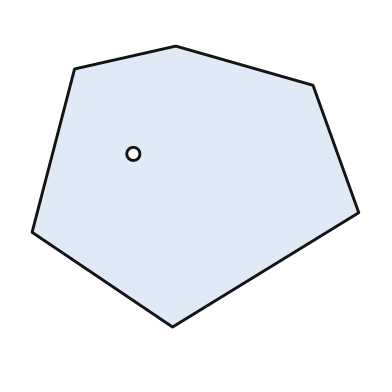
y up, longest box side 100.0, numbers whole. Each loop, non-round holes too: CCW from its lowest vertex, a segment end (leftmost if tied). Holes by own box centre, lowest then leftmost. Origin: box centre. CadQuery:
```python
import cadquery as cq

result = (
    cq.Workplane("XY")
    .moveTo(-7.0, -43.0)
    .lineTo(50.0, -8.0)
    .lineTo(36.0, 31.0)
    .lineTo(-6.0, 43.0)
    .lineTo(-37.0, 36.0)
    .lineTo(-50.0, -14.0)
    .close()
    .moveTo(-19.0, 10.0)
    .circle(2.0)
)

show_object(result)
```